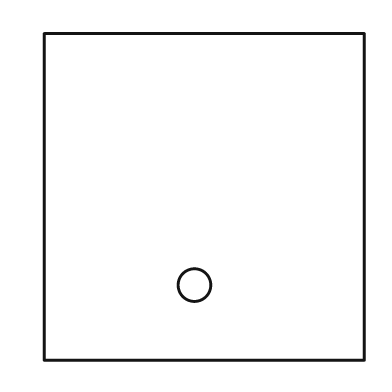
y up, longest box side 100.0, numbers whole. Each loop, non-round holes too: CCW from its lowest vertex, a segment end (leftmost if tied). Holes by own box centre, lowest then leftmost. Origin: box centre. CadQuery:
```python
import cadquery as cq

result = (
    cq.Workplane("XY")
    .moveTo(-49.0, -50.0)
    .lineTo(49.0, -50.0)
    .lineTo(49.0, 50.0)
    .lineTo(-49.0, 50.0)
    .close()
    .moveTo(-3.0, -27.0)
    .circle(5.0)
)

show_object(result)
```